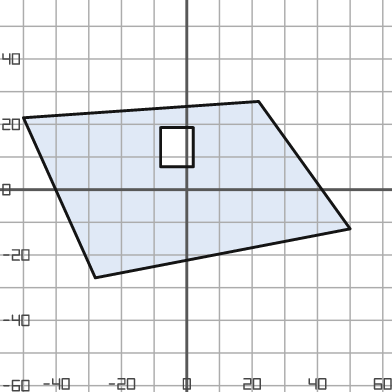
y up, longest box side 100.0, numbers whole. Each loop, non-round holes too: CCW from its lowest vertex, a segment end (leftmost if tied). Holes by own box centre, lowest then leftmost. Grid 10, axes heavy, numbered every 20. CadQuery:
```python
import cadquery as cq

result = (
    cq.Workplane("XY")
    .moveTo(-28.0, -27.0)
    .lineTo(50.0, -12.0)
    .lineTo(22.0, 27.0)
    .lineTo(-50.0, 22.0)
    .close()
    .moveTo(-8.0, 7.0)
    .lineTo(2.0, 7.0)
    .lineTo(2.0, 19.0)
    .lineTo(-8.0, 19.0)
    .close()
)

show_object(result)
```